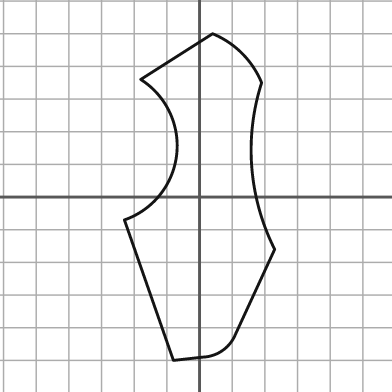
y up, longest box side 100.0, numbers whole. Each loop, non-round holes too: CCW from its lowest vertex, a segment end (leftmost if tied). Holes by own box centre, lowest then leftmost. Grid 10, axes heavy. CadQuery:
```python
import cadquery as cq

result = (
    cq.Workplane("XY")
    .moveTo(-8.0, -50.0)
    .lineTo(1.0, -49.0)
    .threePointArc((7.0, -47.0), (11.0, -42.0))
    .lineTo(23.0, -16.0)
    .threePointArc((16.0, 9.0), (19.0, 35.0))
    .threePointArc((13.0, 44.0), (4.0, 50.0))
    .lineTo(-18.0, 36.0)
    .threePointArc((-7.0, 13.0), (-23.0, -7.0))
    .close()
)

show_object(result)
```